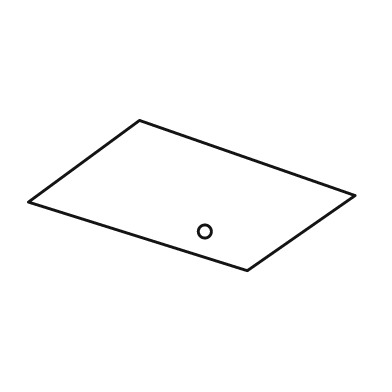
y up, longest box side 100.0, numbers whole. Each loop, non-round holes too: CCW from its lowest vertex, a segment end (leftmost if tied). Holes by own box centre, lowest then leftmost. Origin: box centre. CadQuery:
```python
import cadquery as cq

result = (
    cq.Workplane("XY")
    .moveTo(17.0, -23.0)
    .lineTo(50.0, 0.0)
    .lineTo(-16.0, 23.0)
    .lineTo(-50.0, -2.0)
    .close()
    .moveTo(4.0, -11.0)
    .circle(2.0)
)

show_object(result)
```